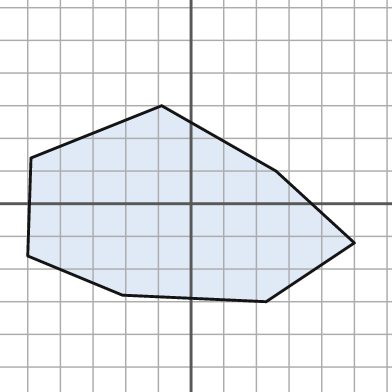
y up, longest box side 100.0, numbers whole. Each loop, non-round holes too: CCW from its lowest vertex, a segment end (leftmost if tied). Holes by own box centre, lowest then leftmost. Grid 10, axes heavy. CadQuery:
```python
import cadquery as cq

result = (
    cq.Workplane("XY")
    .moveTo(23.0, -30.0)
    .lineTo(50.0, -12.0)
    .lineTo(26.0, 10.0)
    .lineTo(-9.0, 30.0)
    .lineTo(-49.0, 14.0)
    .lineTo(-50.0, -16.0)
    .lineTo(-21.0, -28.0)
    .close()
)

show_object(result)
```